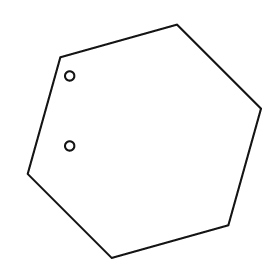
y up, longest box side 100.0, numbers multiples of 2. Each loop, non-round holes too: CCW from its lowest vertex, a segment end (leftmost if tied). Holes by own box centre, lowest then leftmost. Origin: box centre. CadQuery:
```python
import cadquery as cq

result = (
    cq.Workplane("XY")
    .moveTo(-14.0, -50.0)
    .lineTo(36.0, -36.0)
    .lineTo(50.0, 14.0)
    .lineTo(14.0, 50.0)
    .lineTo(-36.0, 36.0)
    .lineTo(-50.0, -14.0)
    .close()
    .moveTo(-32.0, -2.0)
    .circle(2.0)
    .moveTo(-32.0, 28.0)
    .circle(2.0)
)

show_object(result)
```